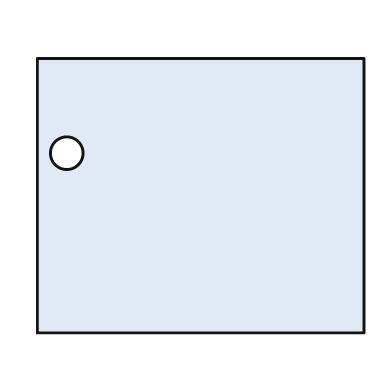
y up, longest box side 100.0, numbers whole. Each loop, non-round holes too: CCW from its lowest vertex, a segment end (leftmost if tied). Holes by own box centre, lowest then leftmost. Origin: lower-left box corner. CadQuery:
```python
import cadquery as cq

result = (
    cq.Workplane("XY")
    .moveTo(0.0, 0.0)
    .lineTo(100.0, 0.0)
    .lineTo(100.0, 84.0)
    .lineTo(0.0, 84.0)
    .close()
    .moveTo(9.0, 55.0)
    .circle(5.0)
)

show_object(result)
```